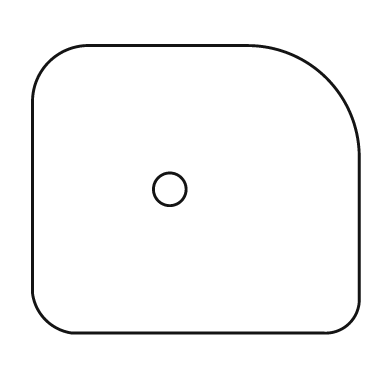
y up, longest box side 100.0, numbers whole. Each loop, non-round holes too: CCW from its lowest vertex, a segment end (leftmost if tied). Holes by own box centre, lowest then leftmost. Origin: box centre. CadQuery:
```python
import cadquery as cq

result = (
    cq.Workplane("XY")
    .moveTo(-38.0, -44.0)
    .lineTo(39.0, -44.0)
    .threePointArc((47.0, -41.0), (50.0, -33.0))
    .lineTo(50.0, 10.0)
    .threePointArc((40.0, 34.0), (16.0, 44.0))
    .lineTo(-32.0, 44.0)
    .threePointArc((-45.0, 39.0), (-50.0, 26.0))
    .lineTo(-50.0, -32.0)
    .threePointArc((-46.0, -40.0), (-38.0, -44.0))
    .close()
    .moveTo(-8.0, 0.0)
    .circle(5.0)
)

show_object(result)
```